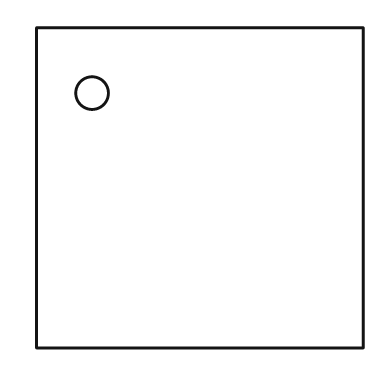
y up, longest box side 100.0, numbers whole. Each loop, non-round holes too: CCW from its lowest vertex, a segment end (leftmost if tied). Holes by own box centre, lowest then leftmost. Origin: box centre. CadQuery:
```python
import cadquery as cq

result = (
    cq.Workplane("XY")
    .moveTo(-50.0, -49.0)
    .lineTo(50.0, -49.0)
    .lineTo(50.0, 49.0)
    .lineTo(-50.0, 49.0)
    .close()
    .moveTo(-33.0, 29.0)
    .circle(5.0)
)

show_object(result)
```